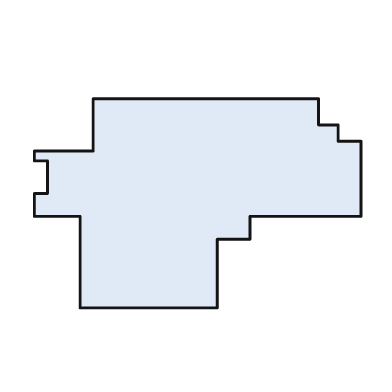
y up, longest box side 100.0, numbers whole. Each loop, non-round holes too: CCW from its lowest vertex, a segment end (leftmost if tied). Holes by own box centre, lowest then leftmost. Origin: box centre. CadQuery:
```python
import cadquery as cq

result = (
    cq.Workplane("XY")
    .moveTo(-36.0, -32.0)
    .lineTo(6.0, -32.0)
    .lineTo(6.0, -11.0)
    .lineTo(16.0, -11.0)
    .lineTo(16.0, -4.0)
    .lineTo(50.0, -4.0)
    .lineTo(50.0, 19.0)
    .lineTo(43.0, 19.0)
    .lineTo(43.0, 24.0)
    .lineTo(37.0, 24.0)
    .lineTo(37.0, 32.0)
    .lineTo(-32.0, 32.0)
    .lineTo(-32.0, 16.0)
    .lineTo(-50.0, 16.0)
    .lineTo(-50.0, 13.0)
    .lineTo(-46.0, 13.0)
    .lineTo(-46.0, 3.0)
    .lineTo(-50.0, 3.0)
    .lineTo(-50.0, -4.0)
    .lineTo(-36.0, -4.0)
    .close()
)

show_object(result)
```